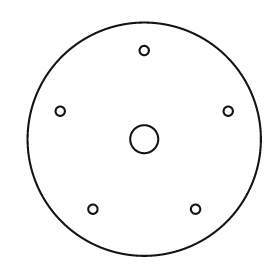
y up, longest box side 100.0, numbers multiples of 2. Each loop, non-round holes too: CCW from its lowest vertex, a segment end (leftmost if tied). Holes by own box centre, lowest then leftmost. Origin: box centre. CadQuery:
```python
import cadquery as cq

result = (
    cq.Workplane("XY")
    .moveTo(0.0, 0.0)
    .circle(50.0)
    .moveTo(-22.0, -30.0)
    .circle(2.0)
    .moveTo(22.0, -30.0)
    .circle(2.0)
    .moveTo(0.0, 0.0)
    .circle(6.0)
    .moveTo(-36.0, 12.0)
    .circle(2.0)
    .moveTo(36.0, 12.0)
    .circle(2.0)
    .moveTo(0.0, 38.0)
    .circle(2.0)
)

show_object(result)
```